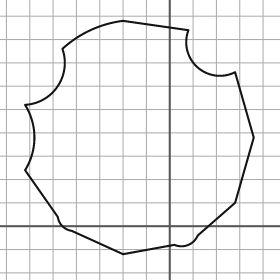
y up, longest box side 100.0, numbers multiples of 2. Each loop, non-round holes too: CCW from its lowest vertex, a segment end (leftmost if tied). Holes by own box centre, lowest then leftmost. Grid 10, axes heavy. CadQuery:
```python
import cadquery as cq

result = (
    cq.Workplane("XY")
    .moveTo(-20.0, -12.0)
    .lineTo(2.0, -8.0)
    .threePointArc((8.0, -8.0), (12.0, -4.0))
    .lineTo(28.0, 10.0)
    .lineTo(36.0, 38.0)
    .lineTo(28.0, 66.0)
    .threePointArc((12.0, 68.0), (8.0, 84.0))
    .lineTo(-20.0, 88.0)
    .threePointArc((-34.0, 84.0), (-46.0, 76.0))
    .threePointArc((-48.0, 60.0), (-62.0, 52.0))
    .threePointArc((-58.0, 38.0), (-62.0, 24.0))
    .lineTo(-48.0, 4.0)
    .threePointArc((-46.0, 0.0), (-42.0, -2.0))
    .close()
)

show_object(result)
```